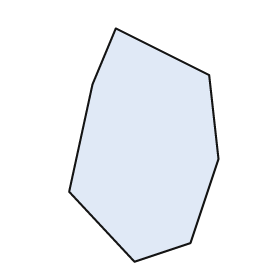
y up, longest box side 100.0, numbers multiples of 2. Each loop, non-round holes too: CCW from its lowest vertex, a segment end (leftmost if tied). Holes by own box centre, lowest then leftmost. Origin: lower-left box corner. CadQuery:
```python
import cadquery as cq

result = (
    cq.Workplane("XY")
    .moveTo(28.0, 0.0)
    .lineTo(52.0, 8.0)
    .lineTo(64.0, 44.0)
    .lineTo(60.0, 80.0)
    .lineTo(20.0, 100.0)
    .lineTo(10.0, 76.0)
    .lineTo(0.0, 30.0)
    .close()
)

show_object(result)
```